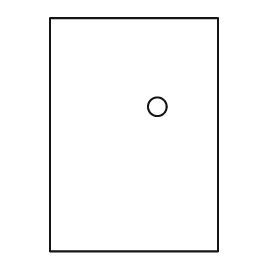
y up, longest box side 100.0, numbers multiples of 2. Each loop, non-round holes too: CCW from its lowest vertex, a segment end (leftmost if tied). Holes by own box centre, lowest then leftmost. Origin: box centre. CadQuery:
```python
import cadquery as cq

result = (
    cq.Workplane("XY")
    .moveTo(-36.0, -50.0)
    .lineTo(36.0, -50.0)
    .lineTo(36.0, 50.0)
    .lineTo(-36.0, 50.0)
    .close()
    .moveTo(10.0, 12.0)
    .circle(4.0)
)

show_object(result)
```